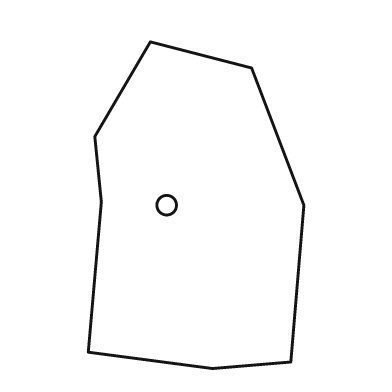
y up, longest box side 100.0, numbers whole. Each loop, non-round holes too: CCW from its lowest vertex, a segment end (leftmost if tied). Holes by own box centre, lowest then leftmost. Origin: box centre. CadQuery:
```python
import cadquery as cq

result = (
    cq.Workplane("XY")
    .moveTo(5.0, -50.0)
    .lineTo(29.0, -48.0)
    .lineTo(33.0, 0.0)
    .lineTo(17.0, 42.0)
    .lineTo(-14.0, 50.0)
    .lineTo(-31.0, 21.0)
    .lineTo(-29.0, 1.0)
    .lineTo(-33.0, -45.0)
    .close()
    .moveTo(-9.0, 0.0)
    .circle(3.0)
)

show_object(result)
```